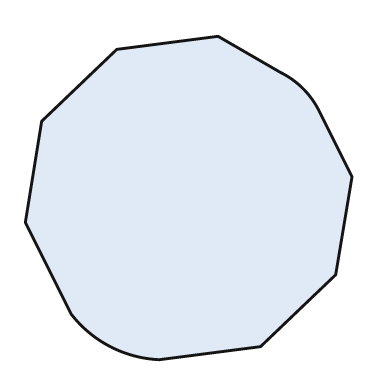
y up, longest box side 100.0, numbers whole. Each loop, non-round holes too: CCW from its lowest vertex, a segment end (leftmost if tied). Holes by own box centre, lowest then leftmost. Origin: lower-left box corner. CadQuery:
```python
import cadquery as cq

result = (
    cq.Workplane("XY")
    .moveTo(41.0, 0.0)
    .lineTo(72.0, 4.0)
    .lineTo(95.0, 26.0)
    .lineTo(100.0, 56.0)
    .lineTo(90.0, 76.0)
    .threePointArc((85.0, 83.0), (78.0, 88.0))
    .lineTo(59.0, 99.0)
    .lineTo(28.0, 95.0)
    .lineTo(5.0, 73.0)
    .lineTo(0.0, 42.0)
    .lineTo(14.0, 14.0)
    .threePointArc((26.0, 4.0), (41.0, 0.0))
    .close()
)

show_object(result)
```